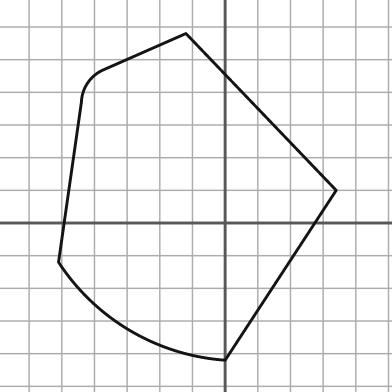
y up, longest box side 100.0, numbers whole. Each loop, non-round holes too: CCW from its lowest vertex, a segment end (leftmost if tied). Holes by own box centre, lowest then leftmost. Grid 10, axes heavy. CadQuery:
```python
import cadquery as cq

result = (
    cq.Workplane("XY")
    .moveTo(0.0, -42.0)
    .lineTo(34.0, 10.0)
    .lineTo(-12.0, 58.0)
    .lineTo(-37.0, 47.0)
    .threePointArc((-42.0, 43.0), (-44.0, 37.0))
    .lineTo(-51.0, -12.0)
    .threePointArc((-29.0, -33.0), (0.0, -42.0))
    .close()
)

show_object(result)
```